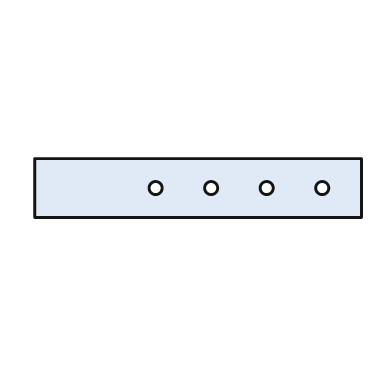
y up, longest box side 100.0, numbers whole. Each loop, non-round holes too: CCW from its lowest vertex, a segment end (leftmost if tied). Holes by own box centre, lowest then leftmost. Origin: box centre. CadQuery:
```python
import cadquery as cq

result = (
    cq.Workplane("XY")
    .moveTo(-50.0, -9.0)
    .lineTo(50.0, -9.0)
    .lineTo(50.0, 9.0)
    .lineTo(-50.0, 9.0)
    .close()
    .moveTo(-13.0, 0.0)
    .circle(2.0)
    .moveTo(4.0, 0.0)
    .circle(2.0)
    .moveTo(21.0, 0.0)
    .circle(2.0)
    .moveTo(38.0, 0.0)
    .circle(2.0)
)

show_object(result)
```